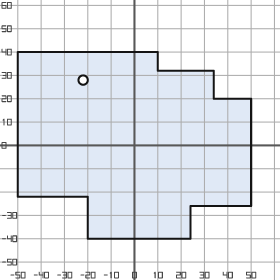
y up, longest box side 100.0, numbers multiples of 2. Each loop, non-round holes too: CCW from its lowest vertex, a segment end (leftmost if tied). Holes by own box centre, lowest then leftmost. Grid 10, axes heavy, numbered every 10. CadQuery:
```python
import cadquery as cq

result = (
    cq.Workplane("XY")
    .moveTo(-20.0, -40.0)
    .lineTo(24.0, -40.0)
    .lineTo(24.0, -26.0)
    .lineTo(50.0, -26.0)
    .lineTo(50.0, 20.0)
    .lineTo(34.0, 20.0)
    .lineTo(34.0, 32.0)
    .lineTo(10.0, 32.0)
    .lineTo(10.0, 40.0)
    .lineTo(-50.0, 40.0)
    .lineTo(-50.0, -22.0)
    .lineTo(-20.0, -22.0)
    .close()
    .moveTo(-22.0, 28.0)
    .circle(2.0)
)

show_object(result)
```